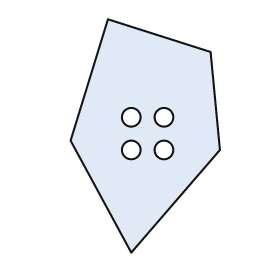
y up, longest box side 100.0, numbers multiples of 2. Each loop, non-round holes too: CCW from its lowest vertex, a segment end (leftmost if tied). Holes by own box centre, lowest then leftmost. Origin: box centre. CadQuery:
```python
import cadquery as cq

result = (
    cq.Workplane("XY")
    .moveTo(-6.0, -50.0)
    .lineTo(32.0, -6.0)
    .lineTo(28.0, 36.0)
    .lineTo(-16.0, 50.0)
    .lineTo(-32.0, -2.0)
    .close()
    .moveTo(-6.0, -6.0)
    .circle(4.0)
    .moveTo(8.0, -6.0)
    .circle(4.0)
    .moveTo(-6.0, 8.0)
    .circle(4.0)
    .moveTo(8.0, 8.0)
    .circle(4.0)
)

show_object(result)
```